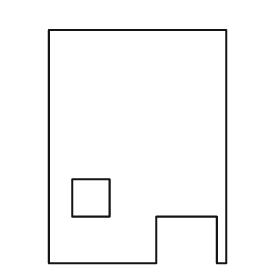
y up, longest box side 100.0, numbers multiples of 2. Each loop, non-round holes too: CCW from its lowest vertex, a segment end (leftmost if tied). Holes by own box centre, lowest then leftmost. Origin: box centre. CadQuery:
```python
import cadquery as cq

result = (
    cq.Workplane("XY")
    .moveTo(-38.0, -50.0)
    .lineTo(8.0, -50.0)
    .lineTo(8.0, -30.0)
    .lineTo(34.0, -30.0)
    .lineTo(34.0, -50.0)
    .lineTo(38.0, -50.0)
    .lineTo(38.0, 50.0)
    .lineTo(-38.0, 50.0)
    .close()
    .moveTo(-28.0, -30.0)
    .lineTo(-12.0, -30.0)
    .lineTo(-12.0, -14.0)
    .lineTo(-28.0, -14.0)
    .close()
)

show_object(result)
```